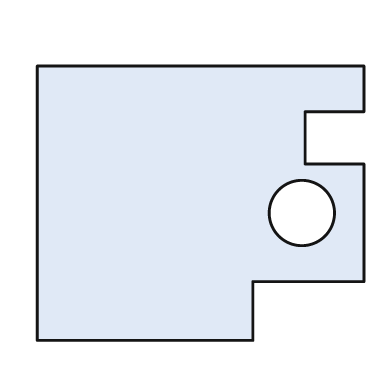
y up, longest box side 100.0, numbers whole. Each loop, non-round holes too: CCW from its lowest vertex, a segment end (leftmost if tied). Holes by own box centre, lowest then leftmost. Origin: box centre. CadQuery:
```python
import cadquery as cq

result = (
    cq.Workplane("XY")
    .moveTo(-50.0, -42.0)
    .lineTo(16.0, -42.0)
    .lineTo(16.0, -24.0)
    .lineTo(50.0, -24.0)
    .lineTo(50.0, 12.0)
    .lineTo(32.0, 12.0)
    .lineTo(32.0, 28.0)
    .lineTo(50.0, 28.0)
    .lineTo(50.0, 42.0)
    .lineTo(-50.0, 42.0)
    .close()
    .moveTo(31.0, -3.0)
    .circle(10.0)
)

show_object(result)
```